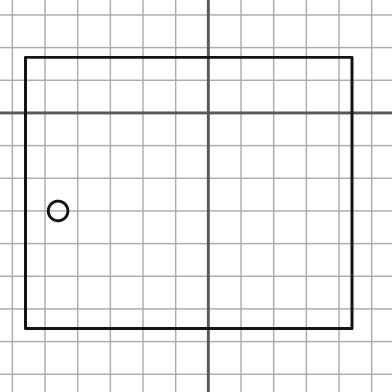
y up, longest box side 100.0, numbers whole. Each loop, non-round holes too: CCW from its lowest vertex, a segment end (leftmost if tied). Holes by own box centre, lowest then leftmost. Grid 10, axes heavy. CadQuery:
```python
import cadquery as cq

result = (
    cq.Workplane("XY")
    .moveTo(-56.0, -66.0)
    .lineTo(44.0, -66.0)
    .lineTo(44.0, 17.0)
    .lineTo(-56.0, 17.0)
    .close()
    .moveTo(-46.0, -30.0)
    .circle(3.0)
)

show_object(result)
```